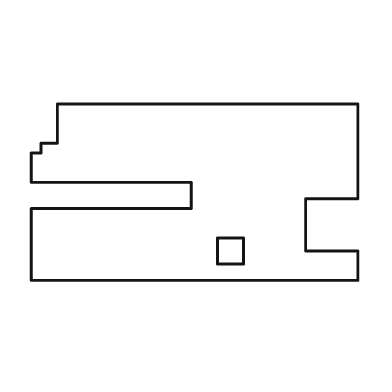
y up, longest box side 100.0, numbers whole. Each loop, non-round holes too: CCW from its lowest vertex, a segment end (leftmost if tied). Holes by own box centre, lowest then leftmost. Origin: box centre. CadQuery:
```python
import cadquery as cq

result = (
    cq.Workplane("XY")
    .moveTo(-50.0, -27.0)
    .lineTo(50.0, -27.0)
    .lineTo(50.0, -18.0)
    .lineTo(34.0, -18.0)
    .lineTo(34.0, -2.0)
    .lineTo(50.0, -2.0)
    .lineTo(50.0, 27.0)
    .lineTo(-42.0, 27.0)
    .lineTo(-42.0, 15.0)
    .lineTo(-47.0, 15.0)
    .lineTo(-47.0, 12.0)
    .lineTo(-50.0, 12.0)
    .lineTo(-50.0, 3.0)
    .lineTo(-1.0, 3.0)
    .lineTo(-1.0, -5.0)
    .lineTo(-50.0, -5.0)
    .close()
    .moveTo(7.0, -22.0)
    .lineTo(15.0, -22.0)
    .lineTo(15.0, -14.0)
    .lineTo(7.0, -14.0)
    .close()
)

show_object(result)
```